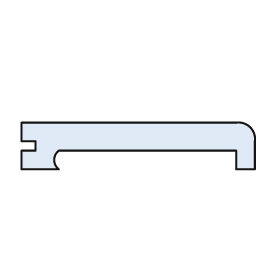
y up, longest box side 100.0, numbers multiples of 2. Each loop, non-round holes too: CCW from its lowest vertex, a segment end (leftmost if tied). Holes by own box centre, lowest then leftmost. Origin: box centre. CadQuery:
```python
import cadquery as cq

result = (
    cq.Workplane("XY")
    .moveTo(-50.0, -10.0)
    .lineTo(-34.0, -10.0)
    .threePointArc((-36.0, -6.0), (-34.0, -2.0))
    .lineTo(42.0, -2.0)
    .lineTo(42.0, -10.0)
    .lineTo(50.0, -10.0)
    .lineTo(50.0, 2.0)
    .threePointArc((48.0, 8.0), (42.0, 10.0))
    .lineTo(-50.0, 10.0)
    .lineTo(-50.0, 2.0)
    .lineTo(-44.0, 2.0)
    .lineTo(-44.0, -2.0)
    .lineTo(-50.0, -2.0)
    .close()
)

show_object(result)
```